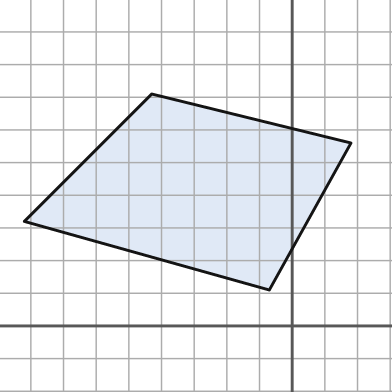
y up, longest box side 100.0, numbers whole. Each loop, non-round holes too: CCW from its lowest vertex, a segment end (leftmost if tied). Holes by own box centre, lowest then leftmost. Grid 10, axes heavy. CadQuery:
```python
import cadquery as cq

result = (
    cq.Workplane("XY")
    .moveTo(-7.0, 11.0)
    .lineTo(18.0, 56.0)
    .lineTo(-43.0, 71.0)
    .lineTo(-82.0, 32.0)
    .close()
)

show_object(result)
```